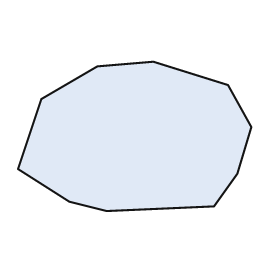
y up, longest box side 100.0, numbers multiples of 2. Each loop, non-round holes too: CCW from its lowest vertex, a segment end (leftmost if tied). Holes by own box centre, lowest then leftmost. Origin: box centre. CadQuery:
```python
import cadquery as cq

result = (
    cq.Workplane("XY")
    .moveTo(-12.0, -32.0)
    .lineTo(34.0, -30.0)
    .lineTo(44.0, -16.0)
    .lineTo(50.0, 4.0)
    .lineTo(40.0, 22.0)
    .lineTo(8.0, 32.0)
    .lineTo(-16.0, 30.0)
    .lineTo(-40.0, 16.0)
    .lineTo(-50.0, -14.0)
    .lineTo(-28.0, -28.0)
    .close()
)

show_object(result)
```